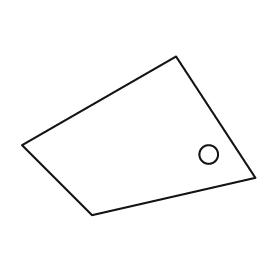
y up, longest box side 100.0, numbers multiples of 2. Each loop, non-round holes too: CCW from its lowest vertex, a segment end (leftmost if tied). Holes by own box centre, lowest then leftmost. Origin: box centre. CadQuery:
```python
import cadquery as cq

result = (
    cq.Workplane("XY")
    .moveTo(-20.0, -34.0)
    .lineTo(50.0, -18.0)
    .lineTo(16.0, 34.0)
    .lineTo(-50.0, -4.0)
    .close()
    .moveTo(30.0, -8.0)
    .circle(4.0)
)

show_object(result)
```